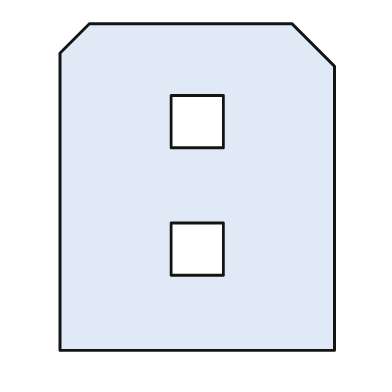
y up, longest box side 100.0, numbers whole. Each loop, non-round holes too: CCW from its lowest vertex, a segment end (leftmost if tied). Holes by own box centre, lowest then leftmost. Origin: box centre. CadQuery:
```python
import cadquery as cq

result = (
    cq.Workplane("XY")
    .moveTo(-42.0, -50.0)
    .lineTo(42.0, -50.0)
    .lineTo(42.0, 37.0)
    .lineTo(29.0, 50.0)
    .lineTo(-33.0, 50.0)
    .lineTo(-42.0, 41.0)
    .close()
    .moveTo(-8.0, -27.0)
    .lineTo(8.0, -27.0)
    .lineTo(8.0, -11.0)
    .lineTo(-8.0, -11.0)
    .close()
    .moveTo(-8.0, 12.0)
    .lineTo(8.0, 12.0)
    .lineTo(8.0, 28.0)
    .lineTo(-8.0, 28.0)
    .close()
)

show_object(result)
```